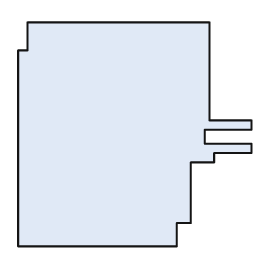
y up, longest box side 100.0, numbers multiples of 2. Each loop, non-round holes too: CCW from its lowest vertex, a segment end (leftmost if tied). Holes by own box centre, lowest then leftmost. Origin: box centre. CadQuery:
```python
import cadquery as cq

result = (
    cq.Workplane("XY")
    .moveTo(-50.0, -48.0)
    .lineTo(18.0, -48.0)
    .lineTo(18.0, -38.0)
    .lineTo(24.0, -38.0)
    .lineTo(24.0, -12.0)
    .lineTo(34.0, -12.0)
    .lineTo(34.0, -8.0)
    .lineTo(50.0, -8.0)
    .lineTo(50.0, -4.0)
    .lineTo(30.0, -4.0)
    .lineTo(30.0, 2.0)
    .lineTo(50.0, 2.0)
    .lineTo(50.0, 6.0)
    .lineTo(32.0, 6.0)
    .lineTo(32.0, 48.0)
    .lineTo(-46.0, 48.0)
    .lineTo(-46.0, 36.0)
    .lineTo(-50.0, 36.0)
    .close()
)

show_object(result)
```